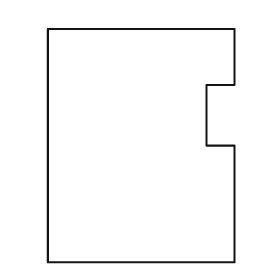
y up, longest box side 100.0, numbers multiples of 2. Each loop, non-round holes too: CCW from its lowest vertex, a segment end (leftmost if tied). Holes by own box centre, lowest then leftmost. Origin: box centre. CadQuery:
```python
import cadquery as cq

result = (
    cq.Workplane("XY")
    .moveTo(-40.0, -50.0)
    .lineTo(40.0, -50.0)
    .lineTo(40.0, 0.0)
    .lineTo(28.0, 0.0)
    .lineTo(28.0, 26.0)
    .lineTo(40.0, 26.0)
    .lineTo(40.0, 50.0)
    .lineTo(-40.0, 50.0)
    .close()
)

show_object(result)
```